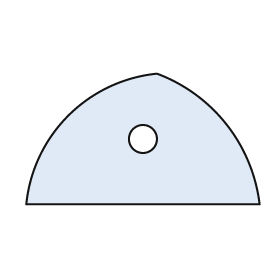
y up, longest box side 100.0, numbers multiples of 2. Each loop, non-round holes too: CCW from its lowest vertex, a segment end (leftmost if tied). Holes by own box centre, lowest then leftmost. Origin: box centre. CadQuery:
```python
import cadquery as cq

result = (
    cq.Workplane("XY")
    .moveTo(-50.0, -28.0)
    .lineTo(50.0, -28.0)
    .threePointArc((36.0, 6.0), (6.0, 28.0))
    .threePointArc((-32.0, 10.0), (-50.0, -28.0))
    .close()
    .moveTo(0.0, 0.0)
    .circle(6.0)
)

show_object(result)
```